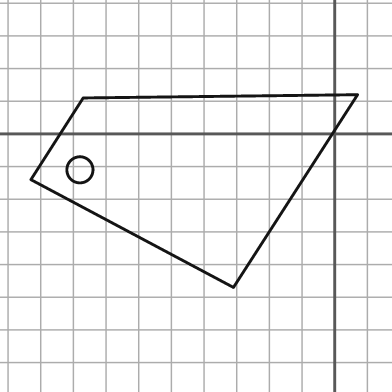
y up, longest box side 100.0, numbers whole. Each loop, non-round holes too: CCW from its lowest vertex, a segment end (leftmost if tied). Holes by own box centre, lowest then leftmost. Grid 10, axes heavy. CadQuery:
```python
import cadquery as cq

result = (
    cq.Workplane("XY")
    .moveTo(-31.0, -47.0)
    .lineTo(7.0, 12.0)
    .lineTo(-77.0, 11.0)
    .lineTo(-93.0, -14.0)
    .close()
    .moveTo(-78.0, -11.0)
    .circle(4.0)
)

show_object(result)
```